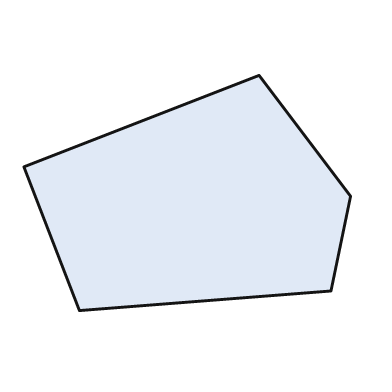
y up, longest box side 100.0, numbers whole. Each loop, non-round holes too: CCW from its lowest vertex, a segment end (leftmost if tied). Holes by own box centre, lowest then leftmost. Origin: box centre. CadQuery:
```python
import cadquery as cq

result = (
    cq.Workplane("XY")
    .moveTo(-33.0, -36.0)
    .lineTo(44.0, -30.0)
    .lineTo(50.0, -1.0)
    .lineTo(22.0, 36.0)
    .lineTo(-50.0, 8.0)
    .close()
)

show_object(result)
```